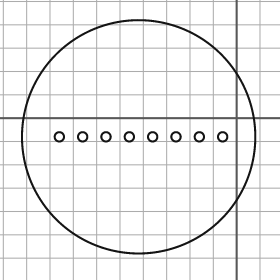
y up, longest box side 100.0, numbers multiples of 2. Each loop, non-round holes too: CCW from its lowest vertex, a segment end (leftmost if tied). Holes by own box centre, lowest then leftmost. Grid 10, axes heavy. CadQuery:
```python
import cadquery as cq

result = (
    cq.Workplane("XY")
    .moveTo(-42.0, -8.0)
    .circle(50.0)
    .moveTo(-76.0, -8.0)
    .circle(2.0)
    .moveTo(-66.0, -8.0)
    .circle(2.0)
    .moveTo(-56.0, -8.0)
    .circle(2.0)
    .moveTo(-46.0, -8.0)
    .circle(2.0)
    .moveTo(-36.0, -8.0)
    .circle(2.0)
    .moveTo(-26.0, -8.0)
    .circle(2.0)
    .moveTo(-16.0, -8.0)
    .circle(2.0)
    .moveTo(-6.0, -8.0)
    .circle(2.0)
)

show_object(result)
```